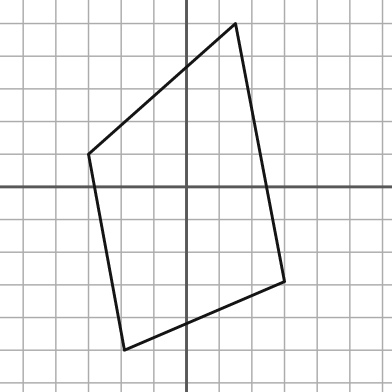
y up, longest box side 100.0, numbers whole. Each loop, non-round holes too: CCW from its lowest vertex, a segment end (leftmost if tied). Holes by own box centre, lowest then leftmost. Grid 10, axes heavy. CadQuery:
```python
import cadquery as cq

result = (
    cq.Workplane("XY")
    .moveTo(-19.0, -50.0)
    .lineTo(30.0, -29.0)
    .lineTo(15.0, 50.0)
    .lineTo(-30.0, 10.0)
    .close()
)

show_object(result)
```